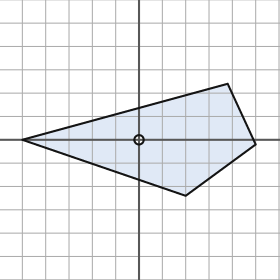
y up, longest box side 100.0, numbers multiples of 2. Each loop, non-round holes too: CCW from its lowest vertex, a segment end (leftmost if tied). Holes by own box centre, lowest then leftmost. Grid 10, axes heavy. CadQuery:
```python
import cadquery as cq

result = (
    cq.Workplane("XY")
    .moveTo(20.0, -24.0)
    .lineTo(50.0, -2.0)
    .lineTo(38.0, 24.0)
    .lineTo(-50.0, 0.0)
    .close()
    .moveTo(0.0, 0.0)
    .circle(2.0)
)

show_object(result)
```